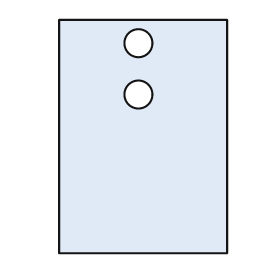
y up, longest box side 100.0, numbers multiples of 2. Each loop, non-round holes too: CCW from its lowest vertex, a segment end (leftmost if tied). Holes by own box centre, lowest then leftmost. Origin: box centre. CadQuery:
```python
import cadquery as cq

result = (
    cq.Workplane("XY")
    .moveTo(-36.0, -50.0)
    .lineTo(36.0, -50.0)
    .lineTo(36.0, 50.0)
    .lineTo(-36.0, 50.0)
    .close()
    .moveTo(-2.0, 18.0)
    .circle(6.0)
    .moveTo(-2.0, 40.0)
    .circle(6.0)
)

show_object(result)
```